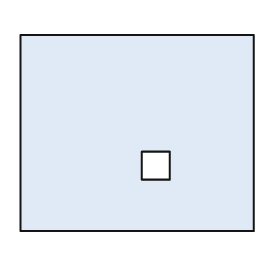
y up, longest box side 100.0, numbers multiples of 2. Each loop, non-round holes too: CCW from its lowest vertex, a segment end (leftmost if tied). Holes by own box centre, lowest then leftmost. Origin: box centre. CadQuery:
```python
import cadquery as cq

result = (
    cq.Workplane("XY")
    .moveTo(-50.0, -42.0)
    .lineTo(50.0, -42.0)
    .lineTo(50.0, 42.0)
    .lineTo(-50.0, 42.0)
    .close()
    .moveTo(2.0, -20.0)
    .lineTo(14.0, -20.0)
    .lineTo(14.0, -8.0)
    .lineTo(2.0, -8.0)
    .close()
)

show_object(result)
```